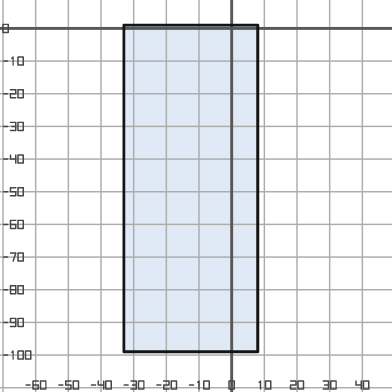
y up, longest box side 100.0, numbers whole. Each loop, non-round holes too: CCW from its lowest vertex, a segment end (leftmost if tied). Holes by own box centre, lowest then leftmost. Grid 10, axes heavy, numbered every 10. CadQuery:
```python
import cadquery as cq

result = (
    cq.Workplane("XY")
    .moveTo(-33.0, -99.0)
    .lineTo(8.0, -99.0)
    .lineTo(8.0, 1.0)
    .lineTo(-33.0, 1.0)
    .close()
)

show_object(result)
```